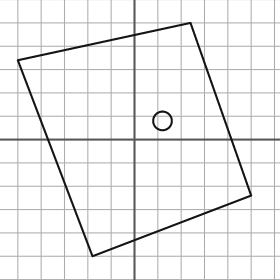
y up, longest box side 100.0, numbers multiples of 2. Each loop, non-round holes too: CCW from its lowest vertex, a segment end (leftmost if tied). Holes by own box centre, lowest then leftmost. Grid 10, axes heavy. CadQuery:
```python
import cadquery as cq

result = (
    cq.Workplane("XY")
    .moveTo(-18.0, -50.0)
    .lineTo(50.0, -24.0)
    .lineTo(24.0, 50.0)
    .lineTo(-50.0, 34.0)
    .close()
    .moveTo(12.0, 8.0)
    .circle(4.0)
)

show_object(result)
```